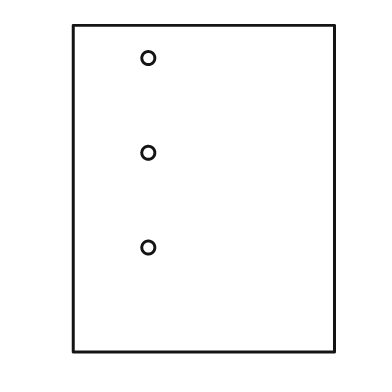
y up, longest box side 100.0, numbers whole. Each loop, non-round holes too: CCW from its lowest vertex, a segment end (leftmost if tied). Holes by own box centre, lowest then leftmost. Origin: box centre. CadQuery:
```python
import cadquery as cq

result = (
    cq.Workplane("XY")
    .moveTo(-40.0, -50.0)
    .lineTo(40.0, -50.0)
    .lineTo(40.0, 50.0)
    .lineTo(-40.0, 50.0)
    .close()
    .moveTo(-17.0, -18.0)
    .circle(2.0)
    .moveTo(-17.0, 11.0)
    .circle(2.0)
    .moveTo(-17.0, 40.0)
    .circle(2.0)
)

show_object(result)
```